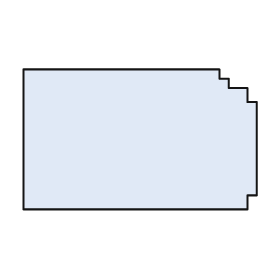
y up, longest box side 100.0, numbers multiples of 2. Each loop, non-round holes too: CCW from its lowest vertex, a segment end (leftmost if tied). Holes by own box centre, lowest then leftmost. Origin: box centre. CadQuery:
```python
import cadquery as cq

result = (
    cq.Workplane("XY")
    .moveTo(-50.0, -30.0)
    .lineTo(46.0, -30.0)
    .lineTo(46.0, -24.0)
    .lineTo(50.0, -24.0)
    .lineTo(50.0, 16.0)
    .lineTo(46.0, 16.0)
    .lineTo(46.0, 22.0)
    .lineTo(38.0, 22.0)
    .lineTo(38.0, 26.0)
    .lineTo(34.0, 26.0)
    .lineTo(34.0, 30.0)
    .lineTo(-50.0, 30.0)
    .close()
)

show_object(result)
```